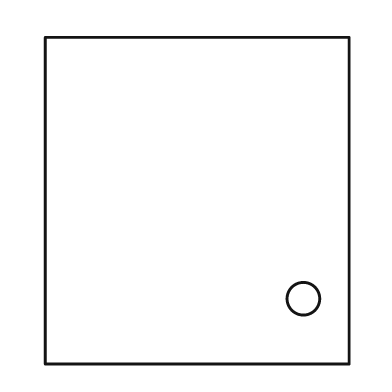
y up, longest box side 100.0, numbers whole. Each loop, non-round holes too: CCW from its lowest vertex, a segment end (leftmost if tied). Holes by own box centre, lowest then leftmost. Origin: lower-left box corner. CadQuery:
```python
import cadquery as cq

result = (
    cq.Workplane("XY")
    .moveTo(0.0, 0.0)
    .lineTo(93.0, 0.0)
    .lineTo(93.0, 100.0)
    .lineTo(0.0, 100.0)
    .close()
    .moveTo(79.0, 20.0)
    .circle(5.0)
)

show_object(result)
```